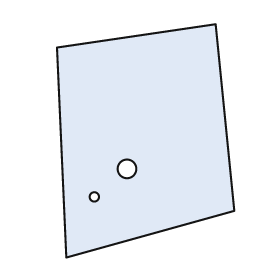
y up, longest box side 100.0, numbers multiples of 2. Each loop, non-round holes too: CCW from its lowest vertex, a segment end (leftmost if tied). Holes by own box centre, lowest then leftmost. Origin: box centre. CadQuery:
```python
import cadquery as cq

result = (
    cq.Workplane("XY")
    .moveTo(-34.0, -50.0)
    .lineTo(38.0, -30.0)
    .lineTo(30.0, 50.0)
    .lineTo(-38.0, 40.0)
    .close()
    .moveTo(-22.0, -24.0)
    .circle(2.0)
    .moveTo(-8.0, -12.0)
    .circle(4.0)
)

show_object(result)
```